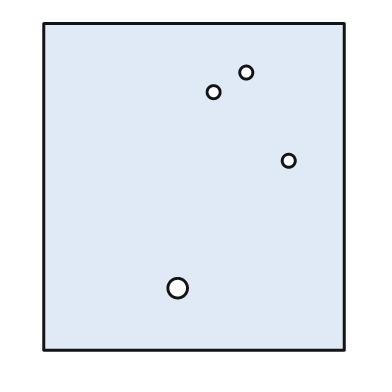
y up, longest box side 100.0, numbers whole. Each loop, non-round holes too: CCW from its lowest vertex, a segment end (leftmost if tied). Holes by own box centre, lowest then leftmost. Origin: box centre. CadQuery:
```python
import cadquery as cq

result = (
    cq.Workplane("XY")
    .moveTo(-46.0, -50.0)
    .lineTo(46.0, -50.0)
    .lineTo(46.0, 50.0)
    .lineTo(-46.0, 50.0)
    .close()
    .moveTo(-5.0, -31.0)
    .circle(3.0)
    .moveTo(29.0, 8.0)
    .circle(2.0)
    .moveTo(6.0, 29.0)
    .circle(2.0)
    .moveTo(16.0, 35.0)
    .circle(2.0)
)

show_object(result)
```